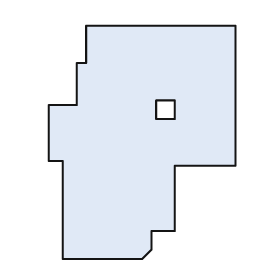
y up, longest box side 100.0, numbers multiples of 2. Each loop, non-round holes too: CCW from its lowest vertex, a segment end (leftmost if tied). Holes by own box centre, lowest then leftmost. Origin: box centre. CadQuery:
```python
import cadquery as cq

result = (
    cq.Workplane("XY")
    .moveTo(-34.0, -50.0)
    .lineTo(0.0, -50.0)
    .lineTo(4.0, -46.0)
    .lineTo(4.0, -38.0)
    .lineTo(14.0, -38.0)
    .lineTo(14.0, -10.0)
    .lineTo(40.0, -10.0)
    .lineTo(40.0, 50.0)
    .lineTo(-24.0, 50.0)
    .lineTo(-24.0, 34.0)
    .lineTo(-28.0, 34.0)
    .lineTo(-28.0, 16.0)
    .lineTo(-40.0, 16.0)
    .lineTo(-40.0, -8.0)
    .lineTo(-34.0, -8.0)
    .close()
    .moveTo(6.0, 10.0)
    .lineTo(14.0, 10.0)
    .lineTo(14.0, 18.0)
    .lineTo(6.0, 18.0)
    .close()
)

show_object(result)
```